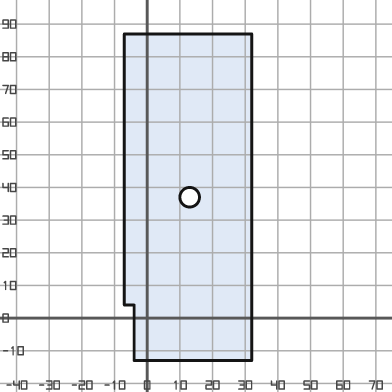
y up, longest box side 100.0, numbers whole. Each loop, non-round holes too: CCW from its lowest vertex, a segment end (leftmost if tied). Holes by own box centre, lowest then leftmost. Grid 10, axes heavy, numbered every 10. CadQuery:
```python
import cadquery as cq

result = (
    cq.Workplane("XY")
    .moveTo(-4.0, -13.0)
    .lineTo(32.0, -13.0)
    .lineTo(32.0, 87.0)
    .lineTo(-7.0, 87.0)
    .lineTo(-7.0, 4.0)
    .lineTo(-4.0, 4.0)
    .close()
    .moveTo(13.0, 37.0)
    .circle(3.0)
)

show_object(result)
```